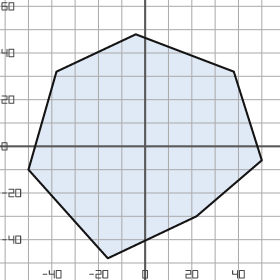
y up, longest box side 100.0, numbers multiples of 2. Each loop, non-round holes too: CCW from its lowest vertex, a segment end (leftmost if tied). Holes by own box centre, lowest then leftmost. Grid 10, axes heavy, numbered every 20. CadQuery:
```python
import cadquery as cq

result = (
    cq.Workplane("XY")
    .moveTo(-16.0, -48.0)
    .lineTo(22.0, -30.0)
    .lineTo(50.0, -6.0)
    .lineTo(38.0, 32.0)
    .lineTo(-4.0, 48.0)
    .lineTo(-38.0, 32.0)
    .lineTo(-50.0, -10.0)
    .close()
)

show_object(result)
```